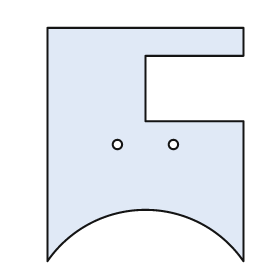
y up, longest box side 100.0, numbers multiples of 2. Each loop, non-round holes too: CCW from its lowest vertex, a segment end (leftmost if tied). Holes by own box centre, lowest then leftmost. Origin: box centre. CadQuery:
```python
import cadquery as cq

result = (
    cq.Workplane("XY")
    .moveTo(-42.0, -50.0)
    .threePointArc((0.0, -28.0), (42.0, -50.0))
    .lineTo(42.0, 10.0)
    .lineTo(0.0, 10.0)
    .lineTo(0.0, 38.0)
    .lineTo(42.0, 38.0)
    .lineTo(42.0, 50.0)
    .lineTo(-42.0, 50.0)
    .close()
    .moveTo(-12.0, 0.0)
    .circle(2.0)
    .moveTo(12.0, 0.0)
    .circle(2.0)
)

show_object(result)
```